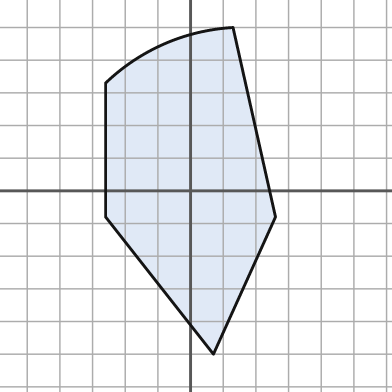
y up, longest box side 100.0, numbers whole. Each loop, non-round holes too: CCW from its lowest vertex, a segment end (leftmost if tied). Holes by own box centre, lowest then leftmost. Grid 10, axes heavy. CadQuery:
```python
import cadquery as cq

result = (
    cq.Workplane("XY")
    .moveTo(7.0, -50.0)
    .lineTo(26.0, -8.0)
    .lineTo(13.0, 50.0)
    .threePointArc((-8.0, 45.0), (-26.0, 33.0))
    .lineTo(-26.0, -8.0)
    .close()
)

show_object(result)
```